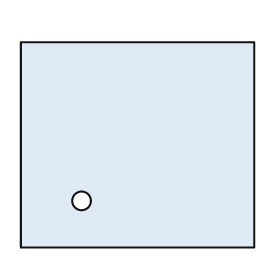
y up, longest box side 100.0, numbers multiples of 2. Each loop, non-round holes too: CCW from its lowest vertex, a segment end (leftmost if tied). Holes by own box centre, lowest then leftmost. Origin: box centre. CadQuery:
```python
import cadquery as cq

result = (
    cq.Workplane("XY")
    .moveTo(-50.0, -44.0)
    .lineTo(50.0, -44.0)
    .lineTo(50.0, 44.0)
    .lineTo(-50.0, 44.0)
    .close()
    .moveTo(-24.0, -24.0)
    .circle(4.0)
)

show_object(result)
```